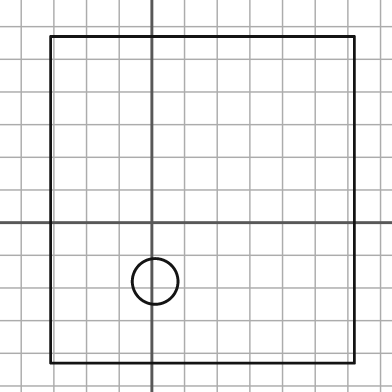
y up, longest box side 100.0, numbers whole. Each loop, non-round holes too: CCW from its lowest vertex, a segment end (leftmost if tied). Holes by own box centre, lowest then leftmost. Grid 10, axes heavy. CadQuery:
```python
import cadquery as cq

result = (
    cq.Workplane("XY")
    .moveTo(-31.0, -43.0)
    .lineTo(62.0, -43.0)
    .lineTo(62.0, 57.0)
    .lineTo(-31.0, 57.0)
    .close()
    .moveTo(1.0, -18.0)
    .circle(7.0)
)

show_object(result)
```